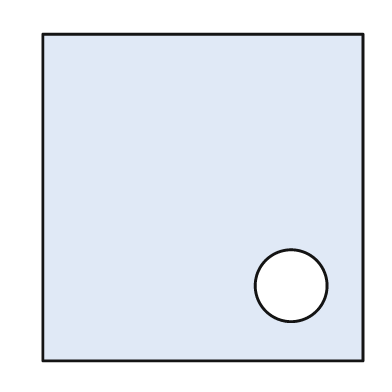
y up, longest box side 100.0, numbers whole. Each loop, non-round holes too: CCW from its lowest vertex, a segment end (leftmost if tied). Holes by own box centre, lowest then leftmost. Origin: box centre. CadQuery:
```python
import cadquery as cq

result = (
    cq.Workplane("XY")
    .moveTo(-49.0, -50.0)
    .lineTo(49.0, -50.0)
    .lineTo(49.0, 50.0)
    .lineTo(-49.0, 50.0)
    .close()
    .moveTo(27.0, -27.0)
    .circle(11.0)
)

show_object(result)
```